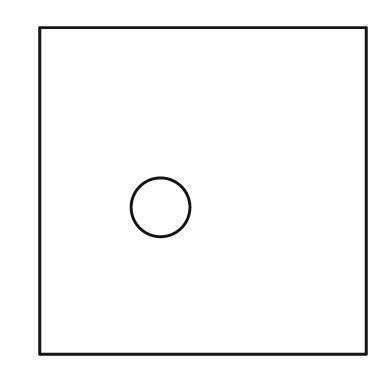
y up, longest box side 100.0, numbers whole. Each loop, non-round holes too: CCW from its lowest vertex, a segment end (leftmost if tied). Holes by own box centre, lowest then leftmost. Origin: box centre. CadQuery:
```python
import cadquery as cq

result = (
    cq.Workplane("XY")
    .moveTo(-50.0, -50.0)
    .lineTo(50.0, -50.0)
    .lineTo(50.0, 50.0)
    .lineTo(-50.0, 50.0)
    .close()
    .moveTo(-13.0, -5.0)
    .circle(9.0)
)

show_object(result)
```